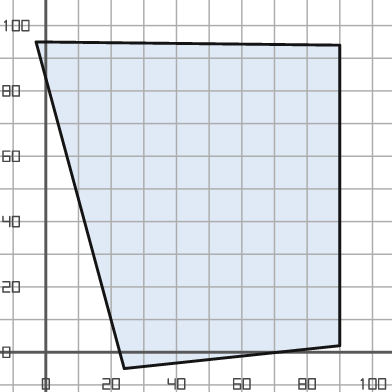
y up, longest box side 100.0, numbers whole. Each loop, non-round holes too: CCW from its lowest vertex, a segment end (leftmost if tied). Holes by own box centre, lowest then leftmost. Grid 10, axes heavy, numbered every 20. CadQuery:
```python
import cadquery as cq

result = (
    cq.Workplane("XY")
    .moveTo(24.0, -5.0)
    .lineTo(90.0, 2.0)
    .lineTo(90.0, 94.0)
    .lineTo(-3.0, 95.0)
    .close()
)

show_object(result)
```